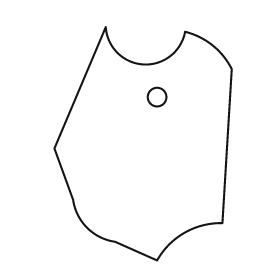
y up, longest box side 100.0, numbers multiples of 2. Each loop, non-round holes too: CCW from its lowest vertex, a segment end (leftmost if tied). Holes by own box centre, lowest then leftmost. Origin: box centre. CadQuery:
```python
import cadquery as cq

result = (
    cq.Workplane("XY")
    .moveTo(6.0, -50.0)
    .threePointArc((18.0, -38.0), (34.0, -34.0))
    .lineTo(38.0, 32.0)
    .threePointArc((30.0, 42.0), (18.0, 48.0))
    .threePointArc((0.0, 34.0), (-16.0, 50.0))
    .lineTo(-38.0, -2.0)
    .lineTo(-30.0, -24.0)
    .threePointArc((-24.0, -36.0), (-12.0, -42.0))
    .close()
    .moveTo(6.0, 20.0)
    .circle(4.0)
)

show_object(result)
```